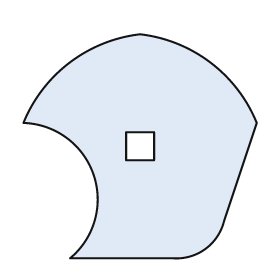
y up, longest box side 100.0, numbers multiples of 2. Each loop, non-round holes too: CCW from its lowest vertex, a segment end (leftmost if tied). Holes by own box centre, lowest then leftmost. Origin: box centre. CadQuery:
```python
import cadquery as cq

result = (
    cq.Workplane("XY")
    .moveTo(-30.0, -48.0)
    .lineTo(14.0, -48.0)
    .threePointArc((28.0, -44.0), (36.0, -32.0))
    .lineTo(50.0, 10.0)
    .threePointArc((30.0, 36.0), (0.0, 48.0))
    .threePointArc((-30.0, 36.0), (-50.0, 10.0))
    .threePointArc((-20.0, -12.0), (-30.0, -48.0))
    .close()
    .moveTo(-6.0, -6.0)
    .lineTo(6.0, -6.0)
    .lineTo(6.0, 6.0)
    .lineTo(-6.0, 6.0)
    .close()
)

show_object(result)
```